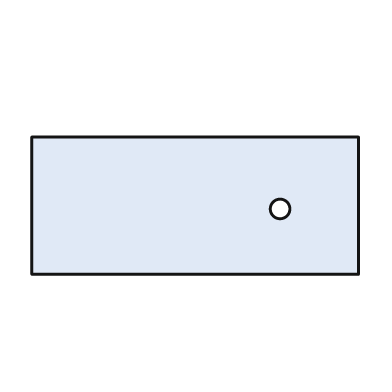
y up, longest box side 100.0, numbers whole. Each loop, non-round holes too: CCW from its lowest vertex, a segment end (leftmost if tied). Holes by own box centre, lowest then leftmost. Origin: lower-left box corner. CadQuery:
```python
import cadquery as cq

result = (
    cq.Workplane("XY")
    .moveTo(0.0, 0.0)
    .lineTo(100.0, 0.0)
    .lineTo(100.0, 42.0)
    .lineTo(0.0, 42.0)
    .close()
    .moveTo(76.0, 20.0)
    .circle(3.0)
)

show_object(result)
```